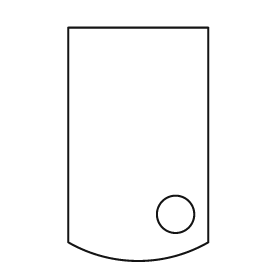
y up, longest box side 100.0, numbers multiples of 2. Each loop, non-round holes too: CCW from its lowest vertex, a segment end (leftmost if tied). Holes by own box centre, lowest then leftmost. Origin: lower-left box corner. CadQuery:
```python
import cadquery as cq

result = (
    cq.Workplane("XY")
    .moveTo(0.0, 8.0)
    .threePointArc((30.0, 0.0), (60.0, 8.0))
    .lineTo(60.0, 100.0)
    .lineTo(0.0, 100.0)
    .close()
    .moveTo(46.0, 20.0)
    .circle(8.0)
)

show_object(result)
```